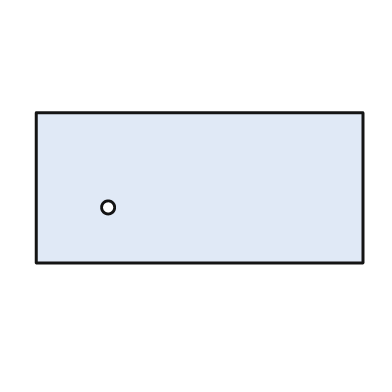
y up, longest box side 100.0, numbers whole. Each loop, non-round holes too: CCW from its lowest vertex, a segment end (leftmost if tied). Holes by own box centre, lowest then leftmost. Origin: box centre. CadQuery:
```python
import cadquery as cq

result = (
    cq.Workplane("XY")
    .moveTo(-50.0, -23.0)
    .lineTo(50.0, -23.0)
    .lineTo(50.0, 23.0)
    .lineTo(-50.0, 23.0)
    .close()
    .moveTo(-28.0, -6.0)
    .circle(2.0)
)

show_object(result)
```